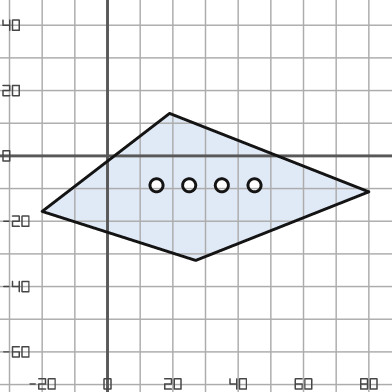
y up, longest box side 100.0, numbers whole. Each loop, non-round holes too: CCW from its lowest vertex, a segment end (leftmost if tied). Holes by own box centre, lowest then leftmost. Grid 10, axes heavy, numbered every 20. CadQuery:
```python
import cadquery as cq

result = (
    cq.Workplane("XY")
    .moveTo(27.0, -32.0)
    .lineTo(80.0, -11.0)
    .lineTo(19.0, 13.0)
    .lineTo(-20.0, -17.0)
    .close()
    .moveTo(15.0, -9.0)
    .circle(2.0)
    .moveTo(25.0, -9.0)
    .circle(2.0)
    .moveTo(35.0, -9.0)
    .circle(2.0)
    .moveTo(45.0, -9.0)
    .circle(2.0)
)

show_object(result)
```